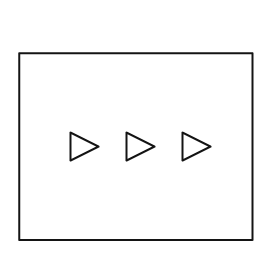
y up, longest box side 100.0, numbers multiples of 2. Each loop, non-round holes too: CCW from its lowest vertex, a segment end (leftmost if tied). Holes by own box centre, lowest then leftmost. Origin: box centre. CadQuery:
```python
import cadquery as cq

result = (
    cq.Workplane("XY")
    .moveTo(-50.0, -40.0)
    .lineTo(50.0, -40.0)
    .lineTo(50.0, 40.0)
    .lineTo(-50.0, 40.0)
    .close()
    .moveTo(-28.0, -6.0)
    .lineTo(-16.0, 0.0)
    .lineTo(-28.0, 6.0)
    .close()
    .moveTo(-4.0, -6.0)
    .lineTo(8.0, 0.0)
    .lineTo(-4.0, 6.0)
    .close()
    .moveTo(20.0, -6.0)
    .lineTo(32.0, 0.0)
    .lineTo(20.0, 6.0)
    .close()
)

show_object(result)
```